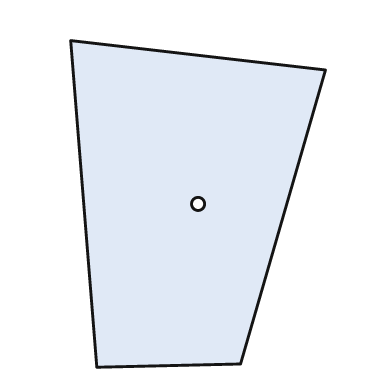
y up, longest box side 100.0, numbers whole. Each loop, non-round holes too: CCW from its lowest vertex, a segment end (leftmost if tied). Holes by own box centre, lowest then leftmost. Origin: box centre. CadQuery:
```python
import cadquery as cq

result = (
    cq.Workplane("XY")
    .moveTo(-31.0, -50.0)
    .lineTo(13.0, -49.0)
    .lineTo(39.0, 41.0)
    .lineTo(-39.0, 50.0)
    .close()
    .moveTo(0.0, 0.0)
    .circle(2.0)
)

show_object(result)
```